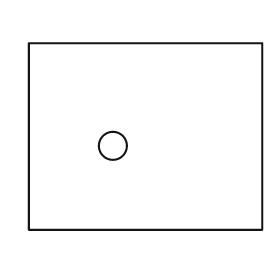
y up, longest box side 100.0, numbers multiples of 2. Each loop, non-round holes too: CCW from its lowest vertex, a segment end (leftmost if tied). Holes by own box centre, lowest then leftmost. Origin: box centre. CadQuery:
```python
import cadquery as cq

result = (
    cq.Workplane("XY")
    .moveTo(-50.0, -40.0)
    .lineTo(50.0, -40.0)
    .lineTo(50.0, 40.0)
    .lineTo(-50.0, 40.0)
    .close()
    .moveTo(-14.0, -4.0)
    .circle(6.0)
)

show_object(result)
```